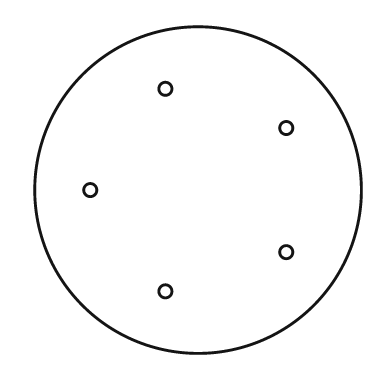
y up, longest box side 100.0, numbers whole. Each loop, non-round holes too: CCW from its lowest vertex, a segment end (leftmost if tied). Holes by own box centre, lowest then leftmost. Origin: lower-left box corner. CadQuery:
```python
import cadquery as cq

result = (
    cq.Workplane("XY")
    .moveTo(50.0, 50.0)
    .circle(50.0)
    .moveTo(40.0, 19.0)
    .circle(2.0)
    .moveTo(77.0, 31.0)
    .circle(2.0)
    .moveTo(17.0, 50.0)
    .circle(2.0)
    .moveTo(77.0, 69.0)
    .circle(2.0)
    .moveTo(40.0, 81.0)
    .circle(2.0)
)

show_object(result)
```